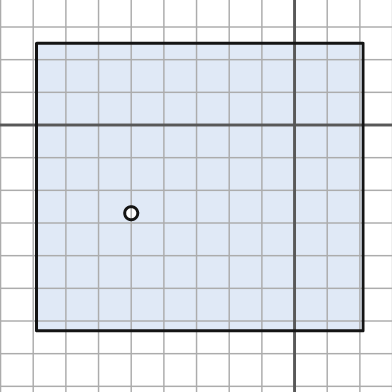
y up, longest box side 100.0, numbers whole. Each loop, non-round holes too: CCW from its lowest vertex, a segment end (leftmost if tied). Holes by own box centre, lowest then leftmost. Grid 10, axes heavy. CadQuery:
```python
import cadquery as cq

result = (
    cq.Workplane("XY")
    .moveTo(-79.0, -63.0)
    .lineTo(21.0, -63.0)
    .lineTo(21.0, 25.0)
    .lineTo(-79.0, 25.0)
    .close()
    .moveTo(-50.0, -27.0)
    .circle(2.0)
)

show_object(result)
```